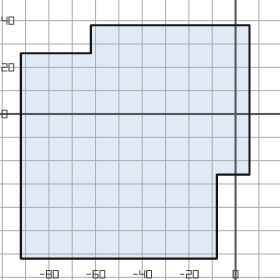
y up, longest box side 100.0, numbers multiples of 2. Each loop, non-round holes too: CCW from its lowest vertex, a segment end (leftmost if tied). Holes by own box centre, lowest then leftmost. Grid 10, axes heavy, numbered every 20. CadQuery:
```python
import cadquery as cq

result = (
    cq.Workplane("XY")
    .moveTo(-92.0, -62.0)
    .lineTo(-8.0, -62.0)
    .lineTo(-8.0, -26.0)
    .lineTo(6.0, -26.0)
    .lineTo(6.0, 38.0)
    .lineTo(-62.0, 38.0)
    .lineTo(-62.0, 26.0)
    .lineTo(-92.0, 26.0)
    .close()
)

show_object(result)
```